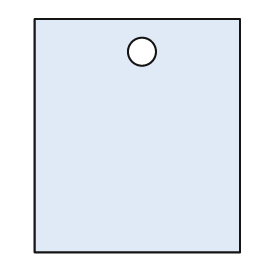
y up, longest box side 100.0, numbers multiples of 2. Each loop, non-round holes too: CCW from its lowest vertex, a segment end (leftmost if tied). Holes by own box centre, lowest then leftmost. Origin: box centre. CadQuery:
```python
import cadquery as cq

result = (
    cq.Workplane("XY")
    .moveTo(-44.0, -50.0)
    .lineTo(44.0, -50.0)
    .lineTo(44.0, 50.0)
    .lineTo(-44.0, 50.0)
    .close()
    .moveTo(2.0, 36.0)
    .circle(6.0)
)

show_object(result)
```